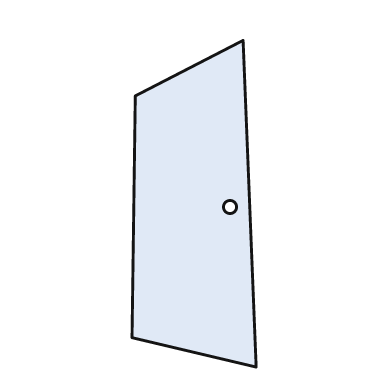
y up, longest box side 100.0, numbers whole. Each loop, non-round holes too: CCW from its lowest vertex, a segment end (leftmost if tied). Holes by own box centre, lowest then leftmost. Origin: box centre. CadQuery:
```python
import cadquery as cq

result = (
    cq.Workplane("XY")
    .moveTo(19.0, -50.0)
    .lineTo(15.0, 50.0)
    .lineTo(-18.0, 33.0)
    .lineTo(-19.0, -41.0)
    .close()
    .moveTo(11.0, -1.0)
    .circle(2.0)
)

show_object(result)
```